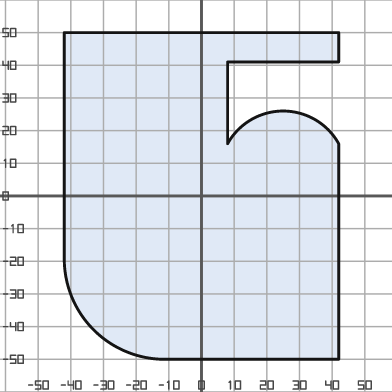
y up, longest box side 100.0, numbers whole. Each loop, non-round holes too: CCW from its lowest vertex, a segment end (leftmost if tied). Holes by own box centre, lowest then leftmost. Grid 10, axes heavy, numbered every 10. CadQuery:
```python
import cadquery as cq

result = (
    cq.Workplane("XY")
    .moveTo(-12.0, -50.0)
    .lineTo(42.0, -50.0)
    .lineTo(42.0, 16.0)
    .threePointArc((25.0, 26.0), (8.0, 16.0))
    .lineTo(8.0, 41.0)
    .lineTo(42.0, 41.0)
    .lineTo(42.0, 50.0)
    .lineTo(-42.0, 50.0)
    .lineTo(-42.0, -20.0)
    .threePointArc((-33.0, -41.0), (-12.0, -50.0))
    .close()
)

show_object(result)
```